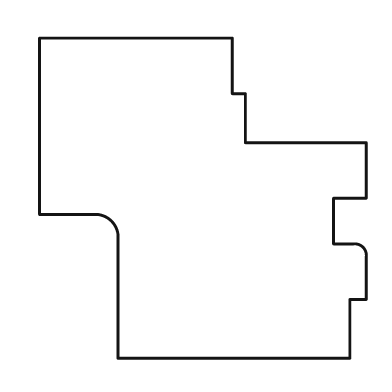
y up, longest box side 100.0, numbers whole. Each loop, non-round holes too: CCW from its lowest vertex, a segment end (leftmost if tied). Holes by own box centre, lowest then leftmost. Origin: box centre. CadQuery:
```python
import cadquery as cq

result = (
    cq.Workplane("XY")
    .moveTo(-26.0, -49.0)
    .lineTo(45.0, -49.0)
    .lineTo(45.0, -31.0)
    .lineTo(50.0, -31.0)
    .lineTo(50.0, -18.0)
    .threePointArc((49.0, -15.0), (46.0, -14.0))
    .lineTo(40.0, -14.0)
    .lineTo(40.0, 0.0)
    .lineTo(50.0, 0.0)
    .lineTo(50.0, 17.0)
    .lineTo(13.0, 17.0)
    .lineTo(13.0, 32.0)
    .lineTo(9.0, 32.0)
    .lineTo(9.0, 49.0)
    .lineTo(-50.0, 49.0)
    .lineTo(-50.0, -5.0)
    .lineTo(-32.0, -5.0)
    .threePointArc((-28.0, -7.0), (-26.0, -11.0))
    .close()
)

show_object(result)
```